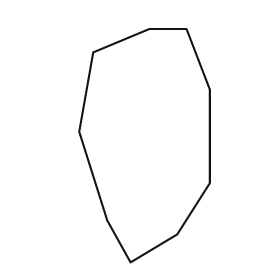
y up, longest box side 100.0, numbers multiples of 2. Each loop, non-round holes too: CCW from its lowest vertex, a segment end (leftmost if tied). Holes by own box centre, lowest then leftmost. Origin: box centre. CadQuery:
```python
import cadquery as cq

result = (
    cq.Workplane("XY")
    .moveTo(-6.0, -50.0)
    .lineTo(14.0, -38.0)
    .lineTo(28.0, -16.0)
    .lineTo(28.0, 24.0)
    .lineTo(18.0, 50.0)
    .lineTo(2.0, 50.0)
    .lineTo(-22.0, 40.0)
    .lineTo(-28.0, 6.0)
    .lineTo(-16.0, -32.0)
    .close()
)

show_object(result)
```